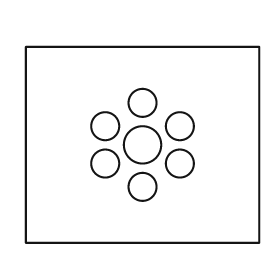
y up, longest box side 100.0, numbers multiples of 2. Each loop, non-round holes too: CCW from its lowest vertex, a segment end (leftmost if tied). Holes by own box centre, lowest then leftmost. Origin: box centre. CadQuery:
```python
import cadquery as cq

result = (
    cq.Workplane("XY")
    .moveTo(-50.0, -42.0)
    .lineTo(50.0, -42.0)
    .lineTo(50.0, 42.0)
    .lineTo(-50.0, 42.0)
    .close()
    .moveTo(0.0, -18.0)
    .circle(6.0)
    .moveTo(-16.0, -8.0)
    .circle(6.0)
    .moveTo(16.0, -8.0)
    .circle(6.0)
    .moveTo(0.0, 0.0)
    .circle(8.0)
    .moveTo(-16.0, 8.0)
    .circle(6.0)
    .moveTo(16.0, 8.0)
    .circle(6.0)
    .moveTo(0.0, 18.0)
    .circle(6.0)
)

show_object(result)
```